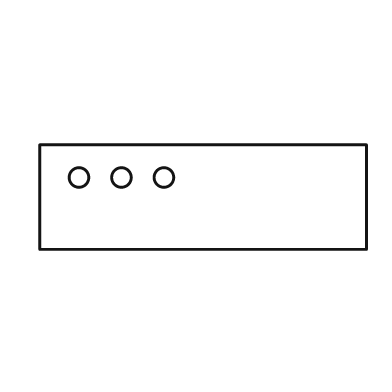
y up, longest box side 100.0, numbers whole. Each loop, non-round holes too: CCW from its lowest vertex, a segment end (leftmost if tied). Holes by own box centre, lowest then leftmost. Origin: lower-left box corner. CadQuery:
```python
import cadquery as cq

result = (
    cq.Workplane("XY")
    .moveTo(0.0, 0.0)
    .lineTo(100.0, 0.0)
    .lineTo(100.0, 32.0)
    .lineTo(0.0, 32.0)
    .close()
    .moveTo(12.0, 22.0)
    .circle(3.0)
    .moveTo(25.0, 22.0)
    .circle(3.0)
    .moveTo(38.0, 22.0)
    .circle(3.0)
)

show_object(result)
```